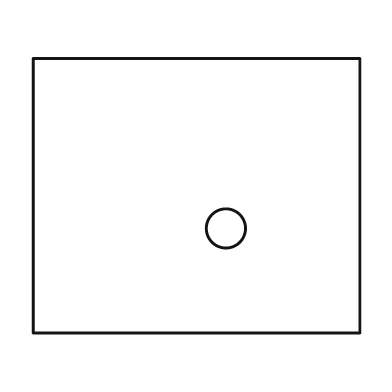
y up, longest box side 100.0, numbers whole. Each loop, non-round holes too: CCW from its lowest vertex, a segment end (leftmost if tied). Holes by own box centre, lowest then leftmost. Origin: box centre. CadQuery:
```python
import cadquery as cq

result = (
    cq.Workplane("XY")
    .moveTo(-50.0, -42.0)
    .lineTo(50.0, -42.0)
    .lineTo(50.0, 42.0)
    .lineTo(-50.0, 42.0)
    .close()
    .moveTo(9.0, -10.0)
    .circle(6.0)
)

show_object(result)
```